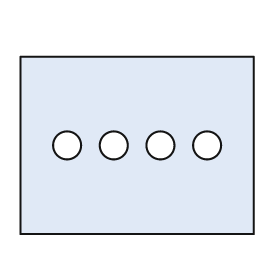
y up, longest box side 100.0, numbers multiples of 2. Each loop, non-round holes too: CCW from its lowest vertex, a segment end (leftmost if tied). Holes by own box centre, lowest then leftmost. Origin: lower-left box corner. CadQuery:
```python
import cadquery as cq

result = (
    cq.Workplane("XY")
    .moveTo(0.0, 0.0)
    .lineTo(100.0, 0.0)
    .lineTo(100.0, 76.0)
    .lineTo(0.0, 76.0)
    .close()
    .moveTo(20.0, 38.0)
    .circle(6.0)
    .moveTo(40.0, 38.0)
    .circle(6.0)
    .moveTo(60.0, 38.0)
    .circle(6.0)
    .moveTo(80.0, 38.0)
    .circle(6.0)
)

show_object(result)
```